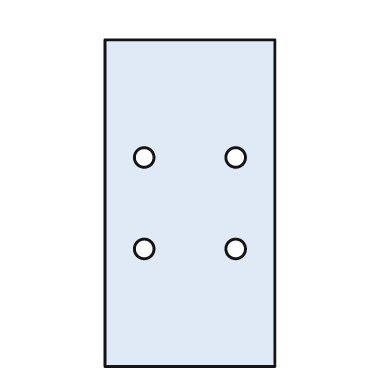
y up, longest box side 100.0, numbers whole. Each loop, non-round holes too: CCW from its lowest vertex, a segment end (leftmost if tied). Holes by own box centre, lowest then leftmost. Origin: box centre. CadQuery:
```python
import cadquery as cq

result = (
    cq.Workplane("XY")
    .moveTo(-26.0, -50.0)
    .lineTo(26.0, -50.0)
    .lineTo(26.0, 50.0)
    .lineTo(-26.0, 50.0)
    .close()
    .moveTo(-14.0, -14.0)
    .circle(3.0)
    .moveTo(14.0, -14.0)
    .circle(3.0)
    .moveTo(-14.0, 14.0)
    .circle(3.0)
    .moveTo(14.0, 14.0)
    .circle(3.0)
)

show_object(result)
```